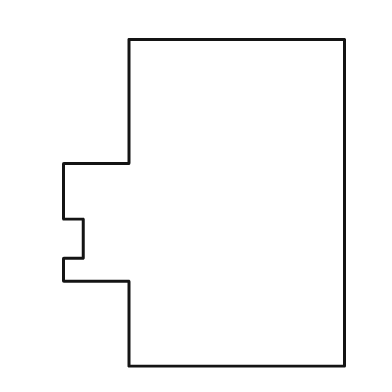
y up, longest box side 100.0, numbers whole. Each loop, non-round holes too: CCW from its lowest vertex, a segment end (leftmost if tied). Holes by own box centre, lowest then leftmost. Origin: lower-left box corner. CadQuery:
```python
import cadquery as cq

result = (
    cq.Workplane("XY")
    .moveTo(20.0, 0.0)
    .lineTo(86.0, 0.0)
    .lineTo(86.0, 100.0)
    .lineTo(20.0, 100.0)
    .lineTo(20.0, 62.0)
    .lineTo(0.0, 62.0)
    .lineTo(0.0, 45.0)
    .lineTo(6.0, 45.0)
    .lineTo(6.0, 33.0)
    .lineTo(0.0, 33.0)
    .lineTo(0.0, 26.0)
    .lineTo(20.0, 26.0)
    .close()
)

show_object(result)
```